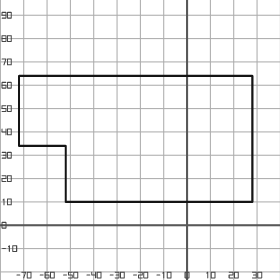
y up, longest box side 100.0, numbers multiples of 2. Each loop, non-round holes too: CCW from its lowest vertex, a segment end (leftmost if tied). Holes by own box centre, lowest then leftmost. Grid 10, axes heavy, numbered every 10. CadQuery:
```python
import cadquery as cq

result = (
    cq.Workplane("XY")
    .moveTo(-52.0, 10.0)
    .lineTo(28.0, 10.0)
    .lineTo(28.0, 64.0)
    .lineTo(-72.0, 64.0)
    .lineTo(-72.0, 34.0)
    .lineTo(-52.0, 34.0)
    .close()
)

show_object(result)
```